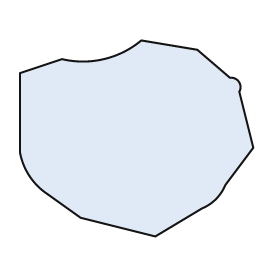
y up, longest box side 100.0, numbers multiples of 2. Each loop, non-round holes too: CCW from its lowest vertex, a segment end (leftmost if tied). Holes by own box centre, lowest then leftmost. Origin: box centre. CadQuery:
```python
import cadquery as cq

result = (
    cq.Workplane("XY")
    .moveTo(8.0, -42.0)
    .lineTo(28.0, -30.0)
    .threePointArc((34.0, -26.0), (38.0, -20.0))
    .lineTo(50.0, -4.0)
    .lineTo(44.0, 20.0)
    .threePointArc((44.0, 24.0), (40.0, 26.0))
    .lineTo(26.0, 38.0)
    .lineTo(2.0, 42.0)
    .threePointArc((-14.0, 34.0), (-32.0, 34.0))
    .lineTo(-50.0, 28.0)
    .lineTo(-50.0, -6.0)
    .threePointArc((-46.0, -16.0), (-38.0, -24.0))
    .lineTo(-24.0, -34.0)
    .close()
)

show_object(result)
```